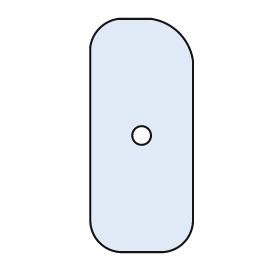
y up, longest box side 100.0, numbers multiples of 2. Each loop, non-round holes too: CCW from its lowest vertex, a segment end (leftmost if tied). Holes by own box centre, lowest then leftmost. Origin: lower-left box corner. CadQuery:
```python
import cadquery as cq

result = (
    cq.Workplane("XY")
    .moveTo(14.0, 0.0)
    .lineTo(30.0, 0.0)
    .threePointArc((40.0, 4.0), (44.0, 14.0))
    .lineTo(44.0, 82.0)
    .threePointArc((38.0, 94.0), (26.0, 100.0))
    .lineTo(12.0, 100.0)
    .threePointArc((4.0, 96.0), (0.0, 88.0))
    .lineTo(0.0, 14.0)
    .threePointArc((4.0, 4.0), (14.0, 0.0))
    .close()
    .moveTo(22.0, 50.0)
    .circle(4.0)
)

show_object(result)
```